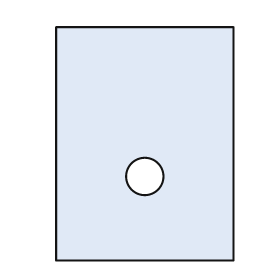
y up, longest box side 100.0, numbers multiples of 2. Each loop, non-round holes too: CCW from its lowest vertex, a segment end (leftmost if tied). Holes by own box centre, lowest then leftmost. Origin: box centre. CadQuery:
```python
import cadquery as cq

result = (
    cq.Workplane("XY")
    .moveTo(-38.0, -50.0)
    .lineTo(38.0, -50.0)
    .lineTo(38.0, 50.0)
    .lineTo(-38.0, 50.0)
    .close()
    .moveTo(0.0, -14.0)
    .circle(8.0)
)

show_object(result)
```